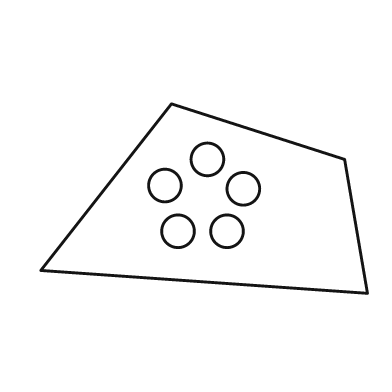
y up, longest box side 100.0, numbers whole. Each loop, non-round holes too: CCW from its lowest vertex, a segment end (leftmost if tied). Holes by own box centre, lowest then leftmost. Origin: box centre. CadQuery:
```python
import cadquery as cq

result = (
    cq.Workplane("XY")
    .moveTo(50.0, -29.0)
    .lineTo(43.0, 12.0)
    .lineTo(-10.0, 29.0)
    .lineTo(-50.0, -22.0)
    .close()
    .moveTo(-8.0, -10.0)
    .circle(5.0)
    .moveTo(7.0, -10.0)
    .circle(5.0)
    .moveTo(12.0, 3.0)
    .circle(5.0)
    .moveTo(-12.0, 4.0)
    .circle(5.0)
    .moveTo(1.0, 12.0)
    .circle(5.0)
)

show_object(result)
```